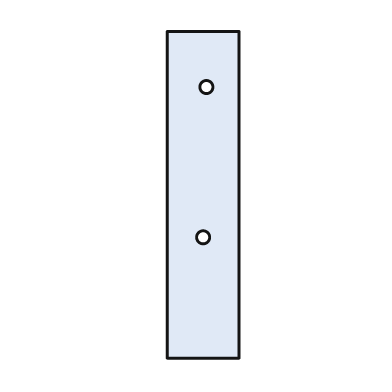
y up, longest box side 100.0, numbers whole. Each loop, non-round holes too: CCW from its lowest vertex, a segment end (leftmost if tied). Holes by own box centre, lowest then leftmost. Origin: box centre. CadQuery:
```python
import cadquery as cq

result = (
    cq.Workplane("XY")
    .moveTo(-11.0, -50.0)
    .lineTo(11.0, -50.0)
    .lineTo(11.0, 50.0)
    .lineTo(-11.0, 50.0)
    .close()
    .moveTo(0.0, -13.0)
    .circle(2.0)
    .moveTo(1.0, 33.0)
    .circle(2.0)
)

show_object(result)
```